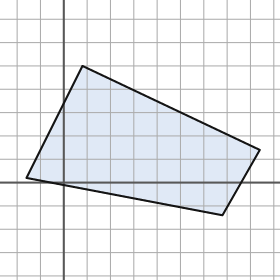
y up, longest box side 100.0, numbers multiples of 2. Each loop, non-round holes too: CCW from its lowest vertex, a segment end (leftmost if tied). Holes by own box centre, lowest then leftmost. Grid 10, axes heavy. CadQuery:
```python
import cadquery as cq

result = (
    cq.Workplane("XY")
    .moveTo(68.0, -14.0)
    .lineTo(84.0, 14.0)
    .lineTo(8.0, 50.0)
    .lineTo(-16.0, 2.0)
    .close()
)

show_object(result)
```